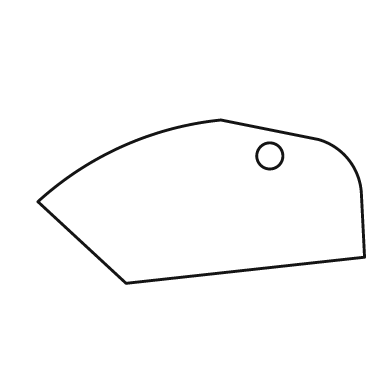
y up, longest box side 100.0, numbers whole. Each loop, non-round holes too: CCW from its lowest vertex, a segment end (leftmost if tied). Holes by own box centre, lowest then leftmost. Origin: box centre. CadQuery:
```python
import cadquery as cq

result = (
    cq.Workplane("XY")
    .moveTo(-23.0, -25.0)
    .lineTo(50.0, -17.0)
    .lineTo(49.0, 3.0)
    .threePointArc((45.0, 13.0), (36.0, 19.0))
    .lineTo(6.0, 25.0)
    .threePointArc((-24.0, 17.0), (-50.0, 0.0))
    .close()
    .moveTo(21.0, 14.0)
    .circle(4.0)
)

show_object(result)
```